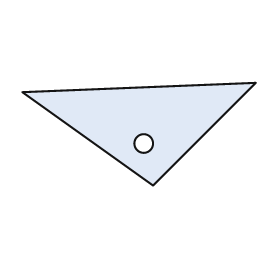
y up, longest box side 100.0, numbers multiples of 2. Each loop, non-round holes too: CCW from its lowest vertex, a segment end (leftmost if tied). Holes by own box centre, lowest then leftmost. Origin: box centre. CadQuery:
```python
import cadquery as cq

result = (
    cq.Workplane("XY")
    .moveTo(6.0, -22.0)
    .lineTo(50.0, 22.0)
    .lineTo(-50.0, 18.0)
    .close()
    .moveTo(2.0, -4.0)
    .circle(4.0)
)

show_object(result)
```